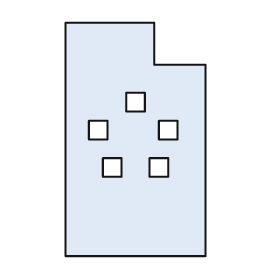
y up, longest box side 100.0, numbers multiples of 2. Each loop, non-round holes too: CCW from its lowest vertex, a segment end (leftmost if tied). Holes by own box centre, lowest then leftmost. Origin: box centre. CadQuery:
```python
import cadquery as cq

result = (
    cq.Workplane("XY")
    .moveTo(-30.0, -50.0)
    .lineTo(30.0, -50.0)
    .lineTo(30.0, 32.0)
    .lineTo(8.0, 32.0)
    .lineTo(8.0, 50.0)
    .lineTo(-30.0, 50.0)
    .close()
    .moveTo(-14.0, -16.0)
    .lineTo(-6.0, -16.0)
    .lineTo(-6.0, -8.0)
    .lineTo(-14.0, -8.0)
    .close()
    .moveTo(6.0, -16.0)
    .lineTo(14.0, -16.0)
    .lineTo(14.0, -8.0)
    .lineTo(6.0, -8.0)
    .close()
    .moveTo(-20.0, 0.0)
    .lineTo(-12.0, 0.0)
    .lineTo(-12.0, 8.0)
    .lineTo(-20.0, 8.0)
    .close()
    .moveTo(10.0, 0.0)
    .lineTo(18.0, 0.0)
    .lineTo(18.0, 8.0)
    .lineTo(10.0, 8.0)
    .close()
    .moveTo(-4.0, 12.0)
    .lineTo(4.0, 12.0)
    .lineTo(4.0, 20.0)
    .lineTo(-4.0, 20.0)
    .close()
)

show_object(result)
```